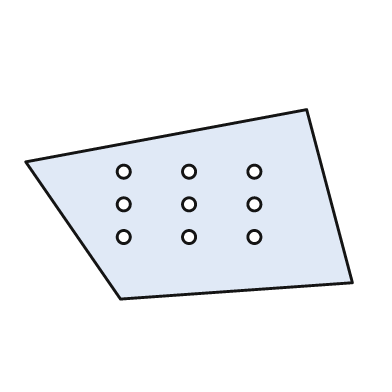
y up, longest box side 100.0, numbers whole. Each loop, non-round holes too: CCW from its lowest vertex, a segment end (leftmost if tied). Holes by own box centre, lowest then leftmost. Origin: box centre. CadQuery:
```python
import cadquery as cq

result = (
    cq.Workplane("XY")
    .moveTo(-21.0, -29.0)
    .lineTo(50.0, -24.0)
    .lineTo(36.0, 29.0)
    .lineTo(-50.0, 13.0)
    .close()
    .moveTo(-20.0, -10.0)
    .circle(2.0)
    .moveTo(0.0, -10.0)
    .circle(2.0)
    .moveTo(20.0, -10.0)
    .circle(2.0)
    .moveTo(-20.0, 0.0)
    .circle(2.0)
    .moveTo(0.0, 0.0)
    .circle(2.0)
    .moveTo(20.0, 0.0)
    .circle(2.0)
    .moveTo(-20.0, 10.0)
    .circle(2.0)
    .moveTo(0.0, 10.0)
    .circle(2.0)
    .moveTo(20.0, 10.0)
    .circle(2.0)
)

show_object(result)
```